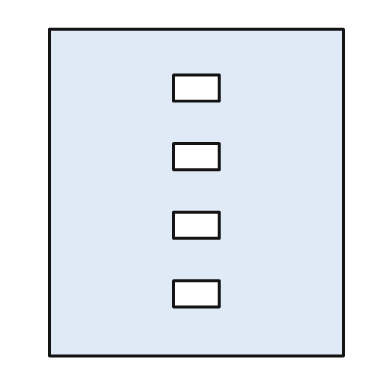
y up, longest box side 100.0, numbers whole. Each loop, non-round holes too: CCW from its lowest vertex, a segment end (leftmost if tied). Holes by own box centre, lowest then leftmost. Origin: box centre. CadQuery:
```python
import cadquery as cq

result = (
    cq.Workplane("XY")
    .moveTo(-45.0, -50.0)
    .lineTo(45.0, -50.0)
    .lineTo(45.0, 50.0)
    .lineTo(-45.0, 50.0)
    .close()
    .moveTo(-7.0, -35.0)
    .lineTo(7.0, -35.0)
    .lineTo(7.0, -27.0)
    .lineTo(-7.0, -27.0)
    .close()
    .moveTo(-7.0, -14.0)
    .lineTo(7.0, -14.0)
    .lineTo(7.0, -6.0)
    .lineTo(-7.0, -6.0)
    .close()
    .moveTo(-7.0, 7.0)
    .lineTo(7.0, 7.0)
    .lineTo(7.0, 15.0)
    .lineTo(-7.0, 15.0)
    .close()
    .moveTo(-7.0, 28.0)
    .lineTo(7.0, 28.0)
    .lineTo(7.0, 36.0)
    .lineTo(-7.0, 36.0)
    .close()
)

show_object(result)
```